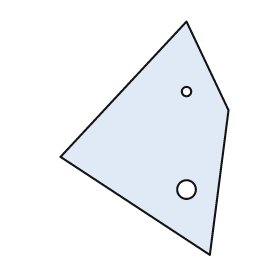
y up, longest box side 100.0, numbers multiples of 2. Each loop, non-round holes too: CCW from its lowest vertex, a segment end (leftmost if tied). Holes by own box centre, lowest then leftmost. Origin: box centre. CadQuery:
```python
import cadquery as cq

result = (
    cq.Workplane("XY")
    .moveTo(28.0, -50.0)
    .lineTo(36.0, 12.0)
    .lineTo(18.0, 50.0)
    .lineTo(-36.0, -8.0)
    .close()
    .moveTo(18.0, -22.0)
    .circle(4.0)
    .moveTo(18.0, 20.0)
    .circle(2.0)
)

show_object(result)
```